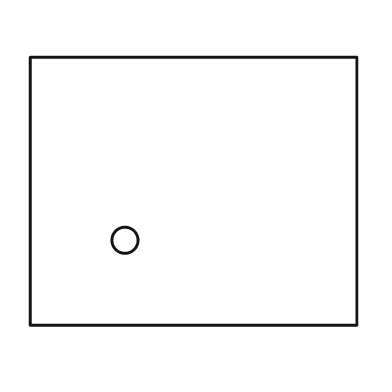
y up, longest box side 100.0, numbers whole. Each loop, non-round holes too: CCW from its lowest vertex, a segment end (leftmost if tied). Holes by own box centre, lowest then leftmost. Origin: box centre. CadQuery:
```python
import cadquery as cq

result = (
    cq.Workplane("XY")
    .moveTo(-50.0, -41.0)
    .lineTo(50.0, -41.0)
    .lineTo(50.0, 41.0)
    .lineTo(-50.0, 41.0)
    .close()
    .moveTo(-21.0, -15.0)
    .circle(4.0)
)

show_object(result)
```